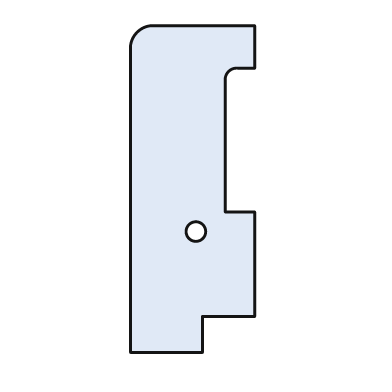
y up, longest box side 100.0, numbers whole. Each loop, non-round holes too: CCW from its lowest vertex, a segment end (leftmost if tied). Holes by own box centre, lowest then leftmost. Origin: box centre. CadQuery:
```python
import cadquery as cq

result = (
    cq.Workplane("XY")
    .moveTo(-19.0, -50.0)
    .lineTo(3.0, -50.0)
    .lineTo(3.0, -39.0)
    .lineTo(19.0, -39.0)
    .lineTo(19.0, -7.0)
    .lineTo(10.0, -7.0)
    .lineTo(10.0, 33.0)
    .threePointArc((11.0, 36.0), (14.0, 37.0))
    .lineTo(19.0, 37.0)
    .lineTo(19.0, 50.0)
    .lineTo(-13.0, 50.0)
    .threePointArc((-17.0, 48.0), (-19.0, 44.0))
    .close()
    .moveTo(1.0, -13.0)
    .circle(3.0)
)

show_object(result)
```